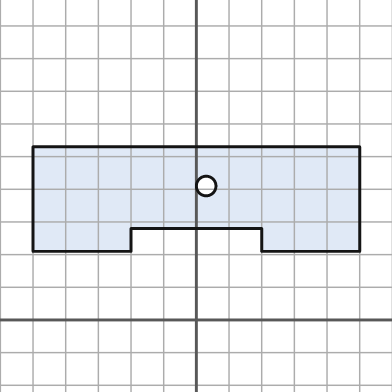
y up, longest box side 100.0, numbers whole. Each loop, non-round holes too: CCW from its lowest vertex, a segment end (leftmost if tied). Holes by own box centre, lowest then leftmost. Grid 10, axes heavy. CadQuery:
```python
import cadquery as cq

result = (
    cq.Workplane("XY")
    .moveTo(-50.0, 21.0)
    .lineTo(-20.0, 21.0)
    .lineTo(-20.0, 28.0)
    .lineTo(20.0, 28.0)
    .lineTo(20.0, 21.0)
    .lineTo(50.0, 21.0)
    .lineTo(50.0, 53.0)
    .lineTo(-50.0, 53.0)
    .close()
    .moveTo(3.0, 41.0)
    .circle(3.0)
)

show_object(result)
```